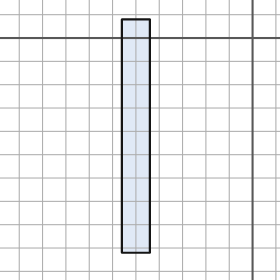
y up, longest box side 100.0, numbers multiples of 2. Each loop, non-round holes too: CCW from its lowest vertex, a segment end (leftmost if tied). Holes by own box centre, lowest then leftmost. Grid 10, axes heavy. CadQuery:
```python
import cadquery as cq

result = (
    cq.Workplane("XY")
    .moveTo(-56.0, -92.0)
    .lineTo(-44.0, -92.0)
    .lineTo(-44.0, 8.0)
    .lineTo(-56.0, 8.0)
    .close()
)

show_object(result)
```